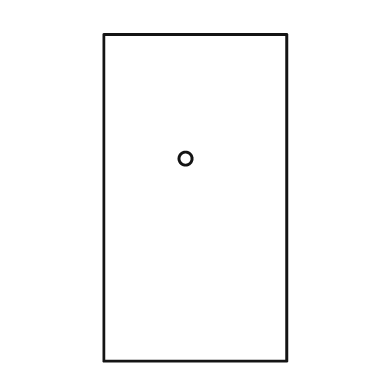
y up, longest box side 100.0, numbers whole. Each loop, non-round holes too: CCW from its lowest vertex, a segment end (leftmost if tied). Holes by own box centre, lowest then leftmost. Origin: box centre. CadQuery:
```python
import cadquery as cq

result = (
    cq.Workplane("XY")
    .moveTo(-28.0, -50.0)
    .lineTo(28.0, -50.0)
    .lineTo(28.0, 50.0)
    .lineTo(-28.0, 50.0)
    .close()
    .moveTo(-3.0, 12.0)
    .circle(2.0)
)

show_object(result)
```